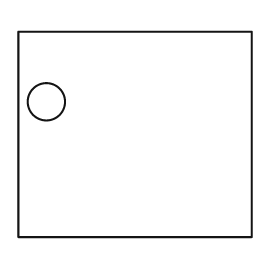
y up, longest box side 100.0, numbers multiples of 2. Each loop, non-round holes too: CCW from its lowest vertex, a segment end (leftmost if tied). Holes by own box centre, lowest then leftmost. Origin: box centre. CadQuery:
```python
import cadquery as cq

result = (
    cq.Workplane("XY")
    .moveTo(-50.0, -44.0)
    .lineTo(50.0, -44.0)
    .lineTo(50.0, 44.0)
    .lineTo(-50.0, 44.0)
    .close()
    .moveTo(-38.0, 14.0)
    .circle(8.0)
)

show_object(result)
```